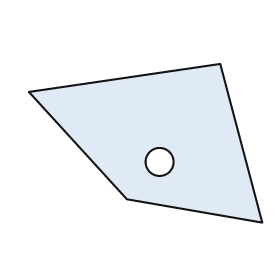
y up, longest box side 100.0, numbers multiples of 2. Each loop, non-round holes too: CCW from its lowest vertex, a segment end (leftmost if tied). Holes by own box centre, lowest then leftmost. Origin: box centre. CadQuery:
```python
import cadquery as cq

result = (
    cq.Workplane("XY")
    .moveTo(50.0, -34.0)
    .lineTo(32.0, 34.0)
    .lineTo(-50.0, 22.0)
    .lineTo(-8.0, -24.0)
    .close()
    .moveTo(6.0, -8.0)
    .circle(6.0)
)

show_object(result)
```